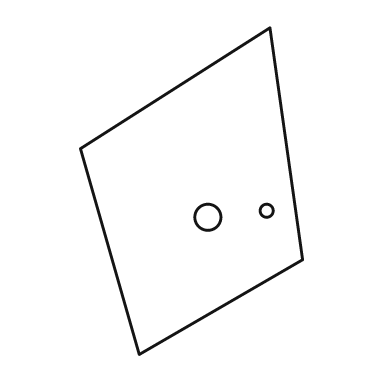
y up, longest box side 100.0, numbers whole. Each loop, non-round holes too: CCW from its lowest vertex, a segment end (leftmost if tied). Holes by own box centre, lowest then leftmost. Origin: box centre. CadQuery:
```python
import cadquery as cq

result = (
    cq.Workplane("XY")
    .moveTo(-16.0, -50.0)
    .lineTo(34.0, -21.0)
    .lineTo(24.0, 50.0)
    .lineTo(-34.0, 13.0)
    .close()
    .moveTo(5.0, -8.0)
    .circle(4.0)
    .moveTo(23.0, -6.0)
    .circle(2.0)
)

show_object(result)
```